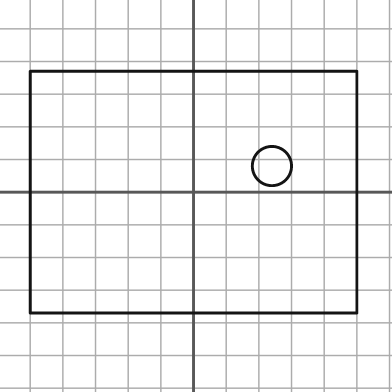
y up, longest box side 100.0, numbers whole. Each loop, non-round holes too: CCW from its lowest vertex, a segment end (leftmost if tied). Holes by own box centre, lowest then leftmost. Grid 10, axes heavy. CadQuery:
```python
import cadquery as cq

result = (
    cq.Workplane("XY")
    .moveTo(-50.0, -37.0)
    .lineTo(50.0, -37.0)
    .lineTo(50.0, 37.0)
    .lineTo(-50.0, 37.0)
    .close()
    .moveTo(24.0, 8.0)
    .circle(6.0)
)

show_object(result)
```